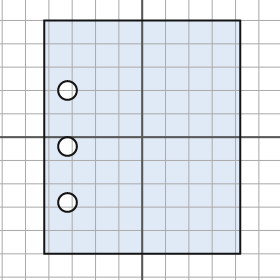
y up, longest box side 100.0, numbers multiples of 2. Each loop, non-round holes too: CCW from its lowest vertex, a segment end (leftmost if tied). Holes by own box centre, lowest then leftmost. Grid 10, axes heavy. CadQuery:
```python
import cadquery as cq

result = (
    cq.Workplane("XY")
    .moveTo(-42.0, -50.0)
    .lineTo(42.0, -50.0)
    .lineTo(42.0, 50.0)
    .lineTo(-42.0, 50.0)
    .close()
    .moveTo(-32.0, -28.0)
    .circle(4.0)
    .moveTo(-32.0, -4.0)
    .circle(4.0)
    .moveTo(-32.0, 20.0)
    .circle(4.0)
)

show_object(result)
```